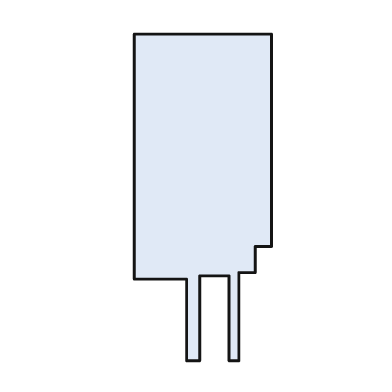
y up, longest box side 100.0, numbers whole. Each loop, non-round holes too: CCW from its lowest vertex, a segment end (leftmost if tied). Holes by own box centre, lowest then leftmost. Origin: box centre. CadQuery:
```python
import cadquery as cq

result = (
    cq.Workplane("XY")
    .moveTo(-5.0, -50.0)
    .lineTo(-1.0, -50.0)
    .lineTo(-1.0, -24.0)
    .lineTo(8.0, -24.0)
    .lineTo(8.0, -50.0)
    .lineTo(11.0, -50.0)
    .lineTo(11.0, -23.0)
    .lineTo(16.0, -23.0)
    .lineTo(16.0, -15.0)
    .lineTo(21.0, -15.0)
    .lineTo(21.0, 50.0)
    .lineTo(-21.0, 50.0)
    .lineTo(-21.0, -25.0)
    .lineTo(-5.0, -25.0)
    .close()
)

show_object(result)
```